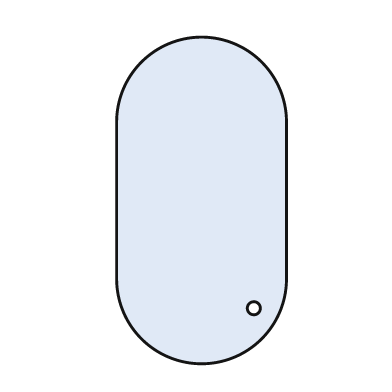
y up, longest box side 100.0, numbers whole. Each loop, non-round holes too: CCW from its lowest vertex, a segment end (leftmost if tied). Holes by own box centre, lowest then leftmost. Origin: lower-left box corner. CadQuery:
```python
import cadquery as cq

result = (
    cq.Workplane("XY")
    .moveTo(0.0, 26.0)
    .threePointArc((26.0, 0.0), (52.0, 26.0))
    .lineTo(52.0, 74.0)
    .threePointArc((26.0, 100.0), (0.0, 74.0))
    .close()
    .moveTo(42.0, 17.0)
    .circle(2.0)
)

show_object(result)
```